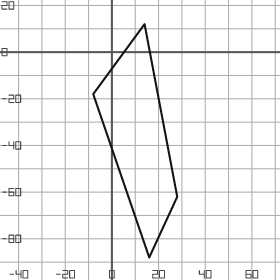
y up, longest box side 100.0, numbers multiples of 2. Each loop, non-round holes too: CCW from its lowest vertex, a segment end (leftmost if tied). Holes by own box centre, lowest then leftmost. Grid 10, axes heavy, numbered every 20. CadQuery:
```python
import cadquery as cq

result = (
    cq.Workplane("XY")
    .moveTo(16.0, -88.0)
    .lineTo(28.0, -62.0)
    .lineTo(14.0, 12.0)
    .lineTo(-8.0, -18.0)
    .close()
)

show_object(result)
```